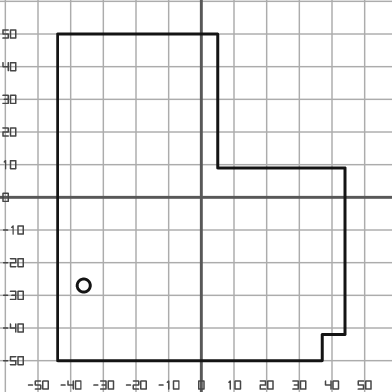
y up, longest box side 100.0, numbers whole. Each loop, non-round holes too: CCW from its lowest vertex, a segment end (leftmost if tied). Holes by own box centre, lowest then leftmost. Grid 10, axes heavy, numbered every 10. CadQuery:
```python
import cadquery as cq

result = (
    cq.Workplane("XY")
    .moveTo(-44.0, -50.0)
    .lineTo(37.0, -50.0)
    .lineTo(37.0, -42.0)
    .lineTo(44.0, -42.0)
    .lineTo(44.0, 9.0)
    .lineTo(5.0, 9.0)
    .lineTo(5.0, 50.0)
    .lineTo(-44.0, 50.0)
    .close()
    .moveTo(-36.0, -27.0)
    .circle(2.0)
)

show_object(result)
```